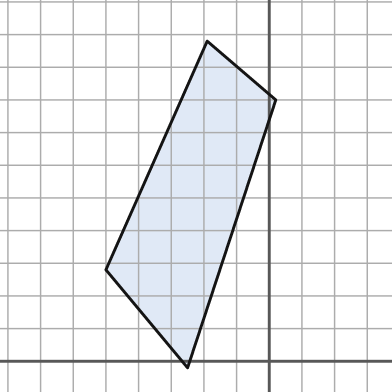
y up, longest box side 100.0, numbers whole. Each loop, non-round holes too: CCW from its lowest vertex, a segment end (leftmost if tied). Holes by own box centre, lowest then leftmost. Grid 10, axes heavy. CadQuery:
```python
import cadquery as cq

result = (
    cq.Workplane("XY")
    .moveTo(-25.0, -2.0)
    .lineTo(2.0, 80.0)
    .lineTo(-19.0, 98.0)
    .lineTo(-50.0, 28.0)
    .close()
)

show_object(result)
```